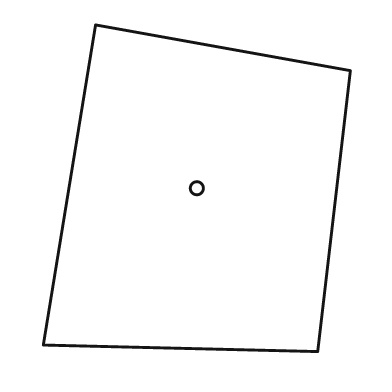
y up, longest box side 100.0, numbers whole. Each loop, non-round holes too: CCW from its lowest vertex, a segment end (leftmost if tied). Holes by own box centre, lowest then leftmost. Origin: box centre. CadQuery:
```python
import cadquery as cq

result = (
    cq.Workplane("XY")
    .moveTo(37.0, -50.0)
    .lineTo(47.0, 36.0)
    .lineTo(-31.0, 50.0)
    .lineTo(-47.0, -48.0)
    .close()
    .moveTo(0.0, 0.0)
    .circle(2.0)
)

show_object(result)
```